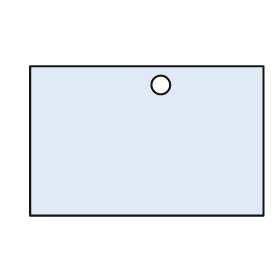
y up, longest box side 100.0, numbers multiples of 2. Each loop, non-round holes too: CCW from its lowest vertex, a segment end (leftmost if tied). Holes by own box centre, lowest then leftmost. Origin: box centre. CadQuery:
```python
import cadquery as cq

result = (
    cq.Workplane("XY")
    .moveTo(-50.0, -32.0)
    .lineTo(50.0, -32.0)
    .lineTo(50.0, 32.0)
    .lineTo(-50.0, 32.0)
    .close()
    .moveTo(6.0, 24.0)
    .circle(4.0)
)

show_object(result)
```